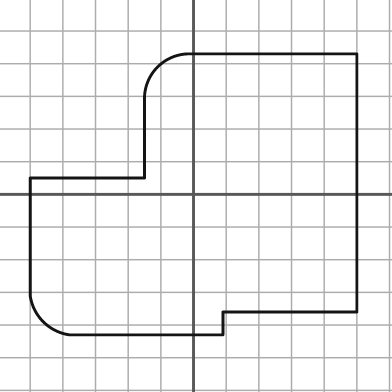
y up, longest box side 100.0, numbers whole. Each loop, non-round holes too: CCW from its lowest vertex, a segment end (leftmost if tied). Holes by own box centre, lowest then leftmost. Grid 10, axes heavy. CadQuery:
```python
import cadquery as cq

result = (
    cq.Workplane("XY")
    .moveTo(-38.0, -43.0)
    .lineTo(9.0, -43.0)
    .lineTo(9.0, -36.0)
    .lineTo(50.0, -36.0)
    .lineTo(50.0, 43.0)
    .lineTo(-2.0, 43.0)
    .threePointArc((-11.0, 39.0), (-15.0, 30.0))
    .lineTo(-15.0, 5.0)
    .lineTo(-50.0, 5.0)
    .lineTo(-50.0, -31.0)
    .threePointArc((-46.0, -39.0), (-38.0, -43.0))
    .close()
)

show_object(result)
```